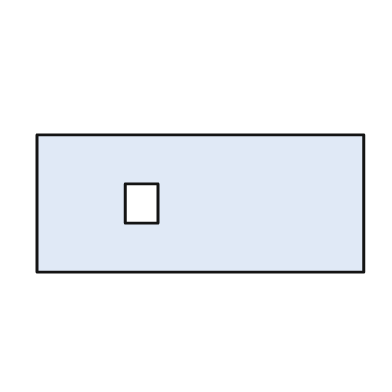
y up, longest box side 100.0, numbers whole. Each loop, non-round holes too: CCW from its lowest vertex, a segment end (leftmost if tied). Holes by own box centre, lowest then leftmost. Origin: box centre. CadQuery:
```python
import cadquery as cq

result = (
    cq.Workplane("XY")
    .moveTo(-50.0, -21.0)
    .lineTo(50.0, -21.0)
    .lineTo(50.0, 21.0)
    .lineTo(-50.0, 21.0)
    .close()
    .moveTo(-23.0, -6.0)
    .lineTo(-13.0, -6.0)
    .lineTo(-13.0, 6.0)
    .lineTo(-23.0, 6.0)
    .close()
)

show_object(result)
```